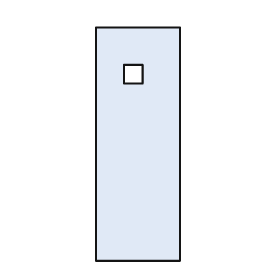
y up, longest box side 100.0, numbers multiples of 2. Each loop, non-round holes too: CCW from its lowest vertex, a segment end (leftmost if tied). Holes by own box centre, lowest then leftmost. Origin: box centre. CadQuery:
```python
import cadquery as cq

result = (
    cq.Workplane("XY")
    .moveTo(-18.0, -50.0)
    .lineTo(18.0, -50.0)
    .lineTo(18.0, 50.0)
    .lineTo(-18.0, 50.0)
    .close()
    .moveTo(-6.0, 26.0)
    .lineTo(2.0, 26.0)
    .lineTo(2.0, 34.0)
    .lineTo(-6.0, 34.0)
    .close()
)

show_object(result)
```